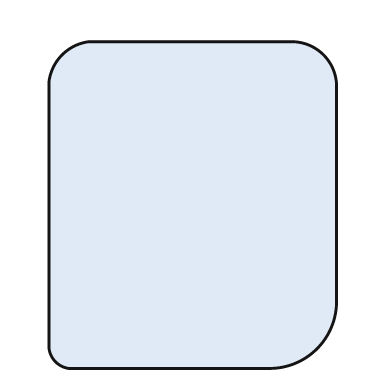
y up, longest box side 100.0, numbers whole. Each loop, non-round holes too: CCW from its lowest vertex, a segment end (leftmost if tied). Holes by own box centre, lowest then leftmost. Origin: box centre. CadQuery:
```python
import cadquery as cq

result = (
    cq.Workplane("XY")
    .moveTo(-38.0, -50.0)
    .lineTo(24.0, -50.0)
    .threePointArc((38.0, -44.0), (44.0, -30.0))
    .lineTo(44.0, 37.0)
    .threePointArc((40.0, 46.0), (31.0, 50.0))
    .lineTo(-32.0, 50.0)
    .threePointArc((-40.0, 46.0), (-44.0, 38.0))
    .lineTo(-44.0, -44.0)
    .threePointArc((-42.0, -48.0), (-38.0, -50.0))
    .close()
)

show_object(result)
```